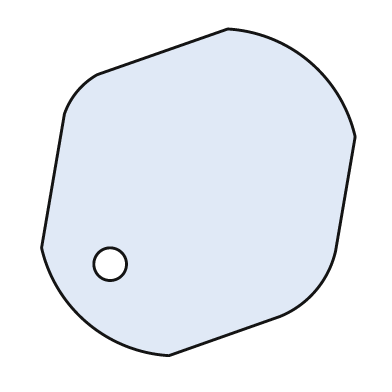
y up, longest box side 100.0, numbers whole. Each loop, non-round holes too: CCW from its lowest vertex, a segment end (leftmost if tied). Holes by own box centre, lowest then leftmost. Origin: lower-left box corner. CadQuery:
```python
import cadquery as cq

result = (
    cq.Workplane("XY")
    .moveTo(39.0, 0.0)
    .lineTo(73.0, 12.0)
    .threePointArc((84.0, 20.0), (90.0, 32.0))
    .lineTo(96.0, 67.0)
    .threePointArc((82.0, 90.0), (57.0, 100.0))
    .lineTo(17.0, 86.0)
    .threePointArc((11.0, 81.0), (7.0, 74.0))
    .lineTo(0.0, 33.0)
    .threePointArc((14.0, 10.0), (39.0, 0.0))
    .close()
    .moveTo(21.0, 28.0)
    .circle(5.0)
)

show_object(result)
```